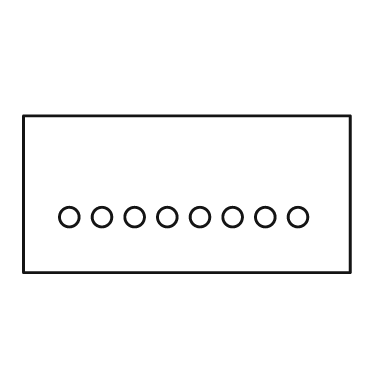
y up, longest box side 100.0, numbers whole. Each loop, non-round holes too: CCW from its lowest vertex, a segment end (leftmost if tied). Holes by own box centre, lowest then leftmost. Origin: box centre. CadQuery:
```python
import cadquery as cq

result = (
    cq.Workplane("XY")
    .moveTo(-50.0, -24.0)
    .lineTo(50.0, -24.0)
    .lineTo(50.0, 24.0)
    .lineTo(-50.0, 24.0)
    .close()
    .moveTo(-36.0, -7.0)
    .circle(3.0)
    .moveTo(-26.0, -7.0)
    .circle(3.0)
    .moveTo(-16.0, -7.0)
    .circle(3.0)
    .moveTo(-6.0, -7.0)
    .circle(3.0)
    .moveTo(4.0, -7.0)
    .circle(3.0)
    .moveTo(14.0, -7.0)
    .circle(3.0)
    .moveTo(24.0, -7.0)
    .circle(3.0)
    .moveTo(34.0, -7.0)
    .circle(3.0)
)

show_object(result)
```